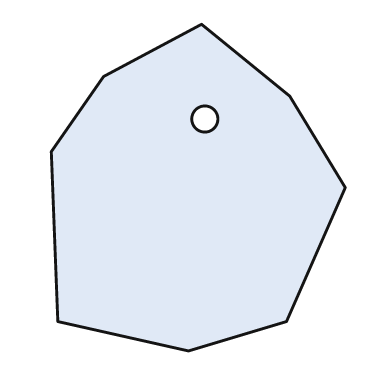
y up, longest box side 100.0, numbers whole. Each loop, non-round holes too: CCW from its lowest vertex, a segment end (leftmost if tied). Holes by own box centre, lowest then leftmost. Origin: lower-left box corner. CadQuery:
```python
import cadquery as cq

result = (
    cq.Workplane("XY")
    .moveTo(42.0, 0.0)
    .lineTo(72.0, 9.0)
    .lineTo(90.0, 50.0)
    .lineTo(73.0, 78.0)
    .lineTo(46.0, 100.0)
    .lineTo(16.0, 84.0)
    .lineTo(0.0, 61.0)
    .lineTo(2.0, 9.0)
    .close()
    .moveTo(47.0, 71.0)
    .circle(4.0)
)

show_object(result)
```